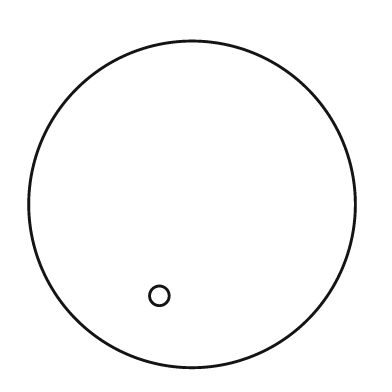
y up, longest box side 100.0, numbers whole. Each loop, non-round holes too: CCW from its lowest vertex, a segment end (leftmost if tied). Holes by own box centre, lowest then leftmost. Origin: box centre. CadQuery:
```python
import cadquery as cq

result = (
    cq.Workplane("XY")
    .moveTo(0.0, 0.0)
    .circle(50.0)
    .moveTo(-10.0, -28.0)
    .circle(3.0)
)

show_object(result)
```